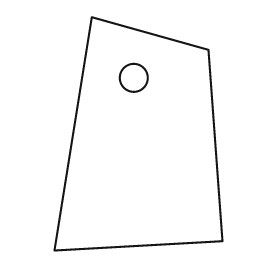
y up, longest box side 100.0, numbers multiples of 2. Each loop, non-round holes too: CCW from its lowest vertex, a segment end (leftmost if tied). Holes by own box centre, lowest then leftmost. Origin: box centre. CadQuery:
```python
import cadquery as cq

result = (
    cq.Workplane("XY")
    .moveTo(-36.0, -50.0)
    .lineTo(36.0, -46.0)
    .lineTo(30.0, 36.0)
    .lineTo(-20.0, 50.0)
    .close()
    .moveTo(-2.0, 24.0)
    .circle(6.0)
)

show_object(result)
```